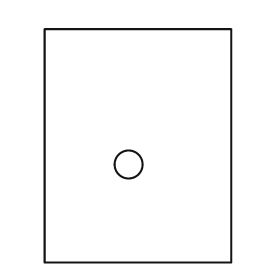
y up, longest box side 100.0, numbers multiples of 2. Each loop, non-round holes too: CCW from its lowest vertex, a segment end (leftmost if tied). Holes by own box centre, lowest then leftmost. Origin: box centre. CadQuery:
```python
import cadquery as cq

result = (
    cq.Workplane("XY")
    .moveTo(-40.0, -50.0)
    .lineTo(40.0, -50.0)
    .lineTo(40.0, 50.0)
    .lineTo(-40.0, 50.0)
    .close()
    .moveTo(-4.0, -8.0)
    .circle(6.0)
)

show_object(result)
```